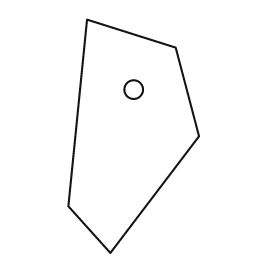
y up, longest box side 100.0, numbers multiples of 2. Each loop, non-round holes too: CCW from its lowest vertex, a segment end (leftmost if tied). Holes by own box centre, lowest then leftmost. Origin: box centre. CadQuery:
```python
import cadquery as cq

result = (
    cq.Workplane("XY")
    .moveTo(-10.0, -50.0)
    .lineTo(28.0, 0.0)
    .lineTo(18.0, 38.0)
    .lineTo(-20.0, 50.0)
    .lineTo(-28.0, -30.0)
    .close()
    .moveTo(0.0, 20.0)
    .circle(4.0)
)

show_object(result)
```